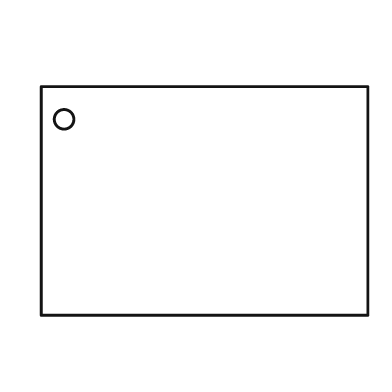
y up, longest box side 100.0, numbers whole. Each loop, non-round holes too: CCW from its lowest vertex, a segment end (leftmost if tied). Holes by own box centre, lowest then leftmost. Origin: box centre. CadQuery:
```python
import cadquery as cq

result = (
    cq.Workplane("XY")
    .moveTo(-50.0, -35.0)
    .lineTo(50.0, -35.0)
    .lineTo(50.0, 35.0)
    .lineTo(-50.0, 35.0)
    .close()
    .moveTo(-43.0, 25.0)
    .circle(3.0)
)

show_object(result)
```